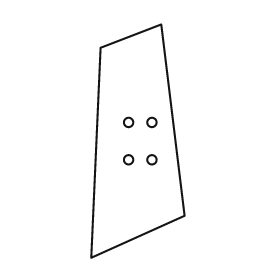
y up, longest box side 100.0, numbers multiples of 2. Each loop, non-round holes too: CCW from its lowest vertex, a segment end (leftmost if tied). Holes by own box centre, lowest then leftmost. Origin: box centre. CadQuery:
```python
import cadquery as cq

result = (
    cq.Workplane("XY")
    .moveTo(-20.0, -50.0)
    .lineTo(20.0, -32.0)
    .lineTo(10.0, 50.0)
    .lineTo(-16.0, 40.0)
    .close()
    .moveTo(-4.0, -8.0)
    .circle(2.0)
    .moveTo(6.0, -8.0)
    .circle(2.0)
    .moveTo(-4.0, 8.0)
    .circle(2.0)
    .moveTo(6.0, 8.0)
    .circle(2.0)
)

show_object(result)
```